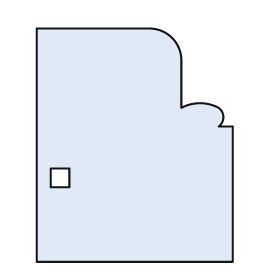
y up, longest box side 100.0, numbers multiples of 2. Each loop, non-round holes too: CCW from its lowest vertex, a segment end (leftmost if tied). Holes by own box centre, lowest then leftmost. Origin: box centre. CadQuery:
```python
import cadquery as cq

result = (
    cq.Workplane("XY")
    .moveTo(-42.0, -50.0)
    .lineTo(42.0, -50.0)
    .lineTo(42.0, 8.0)
    .lineTo(36.0, 8.0)
    .threePointArc((38.0, 12.0), (36.0, 16.0))
    .threePointArc((28.0, 18.0), (20.0, 16.0))
    .lineTo(20.0, 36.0)
    .threePointArc((16.0, 46.0), (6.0, 50.0))
    .lineTo(-42.0, 50.0)
    .close()
    .moveTo(-36.0, -18.0)
    .lineTo(-28.0, -18.0)
    .lineTo(-28.0, -10.0)
    .lineTo(-36.0, -10.0)
    .close()
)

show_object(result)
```